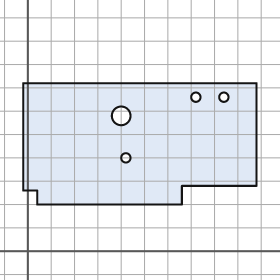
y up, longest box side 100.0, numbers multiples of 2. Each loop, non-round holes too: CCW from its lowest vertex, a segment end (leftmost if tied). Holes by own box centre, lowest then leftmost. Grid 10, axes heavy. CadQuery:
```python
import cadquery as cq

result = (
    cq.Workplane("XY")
    .moveTo(4.0, 20.0)
    .lineTo(66.0, 20.0)
    .lineTo(66.0, 28.0)
    .lineTo(98.0, 28.0)
    .lineTo(98.0, 72.0)
    .lineTo(-2.0, 72.0)
    .lineTo(-2.0, 26.0)
    .lineTo(4.0, 26.0)
    .close()
    .moveTo(42.0, 40.0)
    .circle(2.0)
    .moveTo(40.0, 58.0)
    .circle(4.0)
    .moveTo(72.0, 66.0)
    .circle(2.0)
    .moveTo(84.0, 66.0)
    .circle(2.0)
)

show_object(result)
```